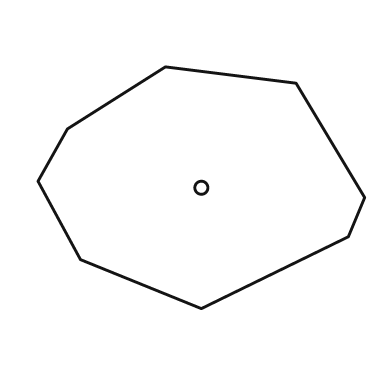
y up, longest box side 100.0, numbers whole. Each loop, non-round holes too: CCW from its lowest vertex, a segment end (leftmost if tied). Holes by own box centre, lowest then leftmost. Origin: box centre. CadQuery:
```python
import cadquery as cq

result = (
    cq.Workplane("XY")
    .moveTo(0.0, -37.0)
    .lineTo(45.0, -15.0)
    .lineTo(50.0, -3.0)
    .lineTo(29.0, 32.0)
    .lineTo(-11.0, 37.0)
    .lineTo(-41.0, 18.0)
    .lineTo(-50.0, 2.0)
    .lineTo(-37.0, -22.0)
    .close()
    .moveTo(0.0, 0.0)
    .circle(2.0)
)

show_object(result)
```